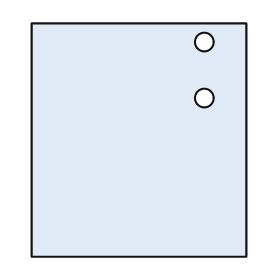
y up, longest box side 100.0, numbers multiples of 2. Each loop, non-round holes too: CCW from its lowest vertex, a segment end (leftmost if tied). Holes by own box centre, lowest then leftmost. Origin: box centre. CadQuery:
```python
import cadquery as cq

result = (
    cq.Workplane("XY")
    .moveTo(-46.0, -50.0)
    .lineTo(46.0, -50.0)
    .lineTo(46.0, 50.0)
    .lineTo(-46.0, 50.0)
    .close()
    .moveTo(28.0, 18.0)
    .circle(4.0)
    .moveTo(28.0, 42.0)
    .circle(4.0)
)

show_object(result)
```